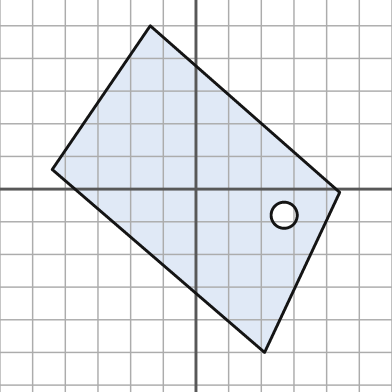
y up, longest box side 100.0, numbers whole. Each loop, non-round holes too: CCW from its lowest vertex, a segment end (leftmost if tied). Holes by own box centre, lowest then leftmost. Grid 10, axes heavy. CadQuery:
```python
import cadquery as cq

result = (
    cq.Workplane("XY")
    .moveTo(21.0, -50.0)
    .lineTo(44.0, -1.0)
    .lineTo(-14.0, 50.0)
    .lineTo(-44.0, 6.0)
    .close()
    .moveTo(27.0, -8.0)
    .circle(4.0)
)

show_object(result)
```